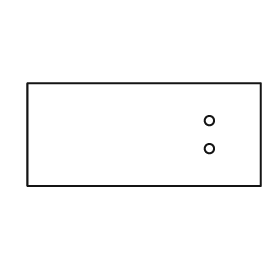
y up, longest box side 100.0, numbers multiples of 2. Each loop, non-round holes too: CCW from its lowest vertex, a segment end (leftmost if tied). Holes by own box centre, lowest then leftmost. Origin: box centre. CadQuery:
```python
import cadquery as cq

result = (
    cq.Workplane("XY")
    .moveTo(-50.0, -22.0)
    .lineTo(50.0, -22.0)
    .lineTo(50.0, 22.0)
    .lineTo(-50.0, 22.0)
    .close()
    .moveTo(28.0, -6.0)
    .circle(2.0)
    .moveTo(28.0, 6.0)
    .circle(2.0)
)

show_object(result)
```